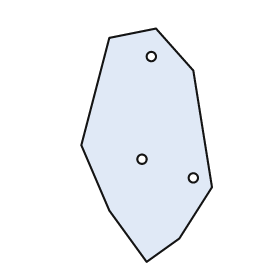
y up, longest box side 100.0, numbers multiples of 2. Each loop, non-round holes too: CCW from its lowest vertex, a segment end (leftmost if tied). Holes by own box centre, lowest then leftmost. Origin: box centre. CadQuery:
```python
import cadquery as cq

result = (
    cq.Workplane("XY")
    .moveTo(0.0, -50.0)
    .lineTo(14.0, -40.0)
    .lineTo(28.0, -18.0)
    .lineTo(20.0, 32.0)
    .lineTo(4.0, 50.0)
    .lineTo(-16.0, 46.0)
    .lineTo(-28.0, 0.0)
    .lineTo(-16.0, -28.0)
    .close()
    .moveTo(20.0, -14.0)
    .circle(2.0)
    .moveTo(-2.0, -6.0)
    .circle(2.0)
    .moveTo(2.0, 38.0)
    .circle(2.0)
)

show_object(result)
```